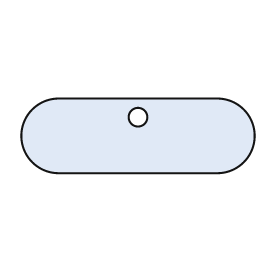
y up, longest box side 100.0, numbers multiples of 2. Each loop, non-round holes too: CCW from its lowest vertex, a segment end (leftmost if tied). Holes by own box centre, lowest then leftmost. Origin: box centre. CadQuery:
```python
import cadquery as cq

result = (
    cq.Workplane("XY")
    .moveTo(-34.0, -16.0)
    .lineTo(34.0, -16.0)
    .threePointArc((50.0, 0.0), (34.0, 16.0))
    .lineTo(-34.0, 16.0)
    .threePointArc((-50.0, 0.0), (-34.0, -16.0))
    .close()
    .moveTo(0.0, 8.0)
    .circle(4.0)
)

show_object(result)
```